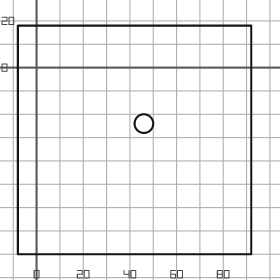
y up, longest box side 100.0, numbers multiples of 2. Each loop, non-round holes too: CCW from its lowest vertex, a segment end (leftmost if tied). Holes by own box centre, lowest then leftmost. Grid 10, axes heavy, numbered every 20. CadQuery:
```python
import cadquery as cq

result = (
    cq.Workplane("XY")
    .moveTo(-8.0, -80.0)
    .lineTo(92.0, -80.0)
    .lineTo(92.0, 18.0)
    .lineTo(-8.0, 18.0)
    .close()
    .moveTo(46.0, -24.0)
    .circle(4.0)
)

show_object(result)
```